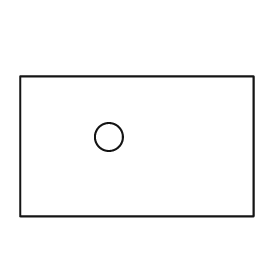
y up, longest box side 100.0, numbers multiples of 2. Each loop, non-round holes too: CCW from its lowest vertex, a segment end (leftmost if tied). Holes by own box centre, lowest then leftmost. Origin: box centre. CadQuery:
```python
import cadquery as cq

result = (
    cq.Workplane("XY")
    .moveTo(-50.0, -30.0)
    .lineTo(50.0, -30.0)
    .lineTo(50.0, 30.0)
    .lineTo(-50.0, 30.0)
    .close()
    .moveTo(-12.0, 4.0)
    .circle(6.0)
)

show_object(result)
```